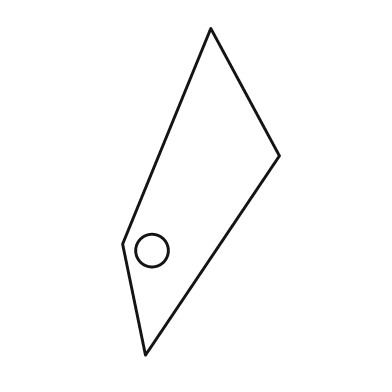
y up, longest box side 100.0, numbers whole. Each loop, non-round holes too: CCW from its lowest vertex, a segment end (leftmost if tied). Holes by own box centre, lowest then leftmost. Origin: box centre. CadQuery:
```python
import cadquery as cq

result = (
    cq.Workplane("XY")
    .moveTo(-17.0, -50.0)
    .lineTo(24.0, 11.0)
    .lineTo(3.0, 50.0)
    .lineTo(-24.0, -16.0)
    .close()
    .moveTo(-15.0, -18.0)
    .circle(5.0)
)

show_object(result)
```